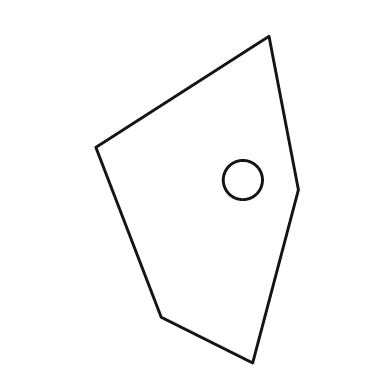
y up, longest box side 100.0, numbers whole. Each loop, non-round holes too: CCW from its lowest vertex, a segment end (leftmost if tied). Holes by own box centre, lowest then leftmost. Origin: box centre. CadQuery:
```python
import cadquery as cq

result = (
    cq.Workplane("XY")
    .moveTo(17.0, -50.0)
    .lineTo(31.0, 3.0)
    .lineTo(22.0, 50.0)
    .lineTo(-31.0, 16.0)
    .lineTo(-11.0, -36.0)
    .close()
    .moveTo(14.0, 6.0)
    .circle(6.0)
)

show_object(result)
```